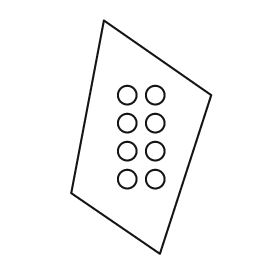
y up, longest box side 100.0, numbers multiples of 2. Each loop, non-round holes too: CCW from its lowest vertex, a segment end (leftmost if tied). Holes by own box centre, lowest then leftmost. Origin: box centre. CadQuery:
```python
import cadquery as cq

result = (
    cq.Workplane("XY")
    .moveTo(8.0, -50.0)
    .lineTo(30.0, 18.0)
    .lineTo(-16.0, 50.0)
    .lineTo(-30.0, -24.0)
    .close()
    .moveTo(-6.0, -18.0)
    .circle(4.0)
    .moveTo(6.0, -18.0)
    .circle(4.0)
    .moveTo(-6.0, -6.0)
    .circle(4.0)
    .moveTo(6.0, -6.0)
    .circle(4.0)
    .moveTo(-6.0, 6.0)
    .circle(4.0)
    .moveTo(6.0, 6.0)
    .circle(4.0)
    .moveTo(-6.0, 18.0)
    .circle(4.0)
    .moveTo(6.0, 18.0)
    .circle(4.0)
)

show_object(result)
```